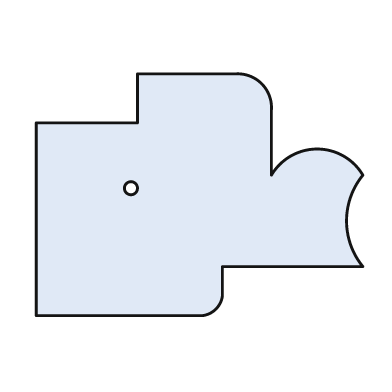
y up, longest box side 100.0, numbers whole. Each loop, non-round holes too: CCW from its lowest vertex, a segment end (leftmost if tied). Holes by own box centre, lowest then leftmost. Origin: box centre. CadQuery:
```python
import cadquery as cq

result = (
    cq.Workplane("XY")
    .moveTo(-50.0, -37.0)
    .lineTo(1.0, -37.0)
    .threePointArc((5.0, -35.0), (7.0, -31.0))
    .lineTo(7.0, -22.0)
    .lineTo(50.0, -22.0)
    .threePointArc((45.0, -8.0), (50.0, 6.0))
    .threePointArc((36.0, 14.0), (22.0, 6.0))
    .lineTo(22.0, 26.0)
    .threePointArc((19.0, 34.0), (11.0, 37.0))
    .lineTo(-19.0, 37.0)
    .lineTo(-19.0, 22.0)
    .lineTo(-50.0, 22.0)
    .close()
    .moveTo(-21.0, 2.0)
    .circle(2.0)
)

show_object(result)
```